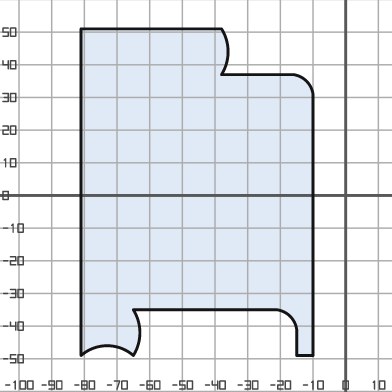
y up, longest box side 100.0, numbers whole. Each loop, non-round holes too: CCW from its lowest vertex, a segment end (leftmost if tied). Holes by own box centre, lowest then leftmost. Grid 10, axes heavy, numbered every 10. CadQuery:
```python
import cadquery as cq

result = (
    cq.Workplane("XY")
    .moveTo(-81.0, -49.0)
    .threePointArc((-73.0, -46.0), (-65.0, -49.0))
    .threePointArc((-63.0, -42.0), (-65.0, -35.0))
    .lineTo(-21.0, -35.0)
    .threePointArc((-17.0, -37.0), (-15.0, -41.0))
    .lineTo(-15.0, -49.0)
    .lineTo(-10.0, -49.0)
    .lineTo(-10.0, 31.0)
    .threePointArc((-12.0, 35.0), (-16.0, 37.0))
    .lineTo(-38.0, 37.0)
    .threePointArc((-36.0, 44.0), (-38.0, 51.0))
    .lineTo(-81.0, 51.0)
    .close()
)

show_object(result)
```